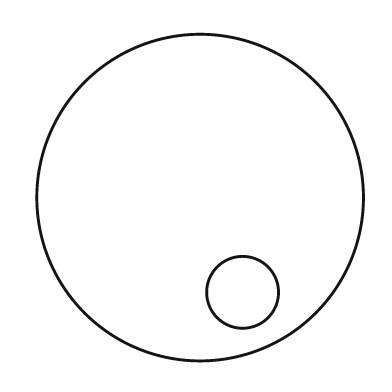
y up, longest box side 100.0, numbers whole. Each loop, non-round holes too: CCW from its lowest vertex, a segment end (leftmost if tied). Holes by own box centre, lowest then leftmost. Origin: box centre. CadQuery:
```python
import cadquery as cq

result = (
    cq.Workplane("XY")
    .moveTo(0.0, 0.0)
    .circle(50.0)
    .moveTo(13.0, -29.0)
    .circle(11.0)
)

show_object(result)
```